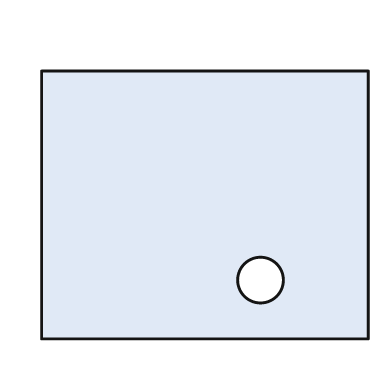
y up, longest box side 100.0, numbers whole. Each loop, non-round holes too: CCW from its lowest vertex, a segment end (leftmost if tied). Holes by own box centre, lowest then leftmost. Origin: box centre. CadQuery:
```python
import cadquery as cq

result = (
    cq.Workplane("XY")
    .moveTo(-50.0, -41.0)
    .lineTo(50.0, -41.0)
    .lineTo(50.0, 41.0)
    .lineTo(-50.0, 41.0)
    .close()
    .moveTo(17.0, -23.0)
    .circle(7.0)
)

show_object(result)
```